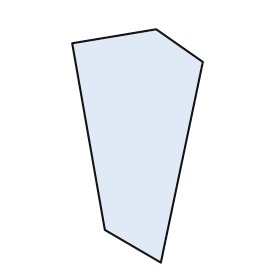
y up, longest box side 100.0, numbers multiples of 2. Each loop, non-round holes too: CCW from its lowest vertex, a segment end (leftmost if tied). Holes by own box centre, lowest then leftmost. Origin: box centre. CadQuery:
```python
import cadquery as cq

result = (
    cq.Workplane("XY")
    .moveTo(10.0, -50.0)
    .lineTo(28.0, 36.0)
    .lineTo(8.0, 50.0)
    .lineTo(-28.0, 44.0)
    .lineTo(-14.0, -36.0)
    .close()
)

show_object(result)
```